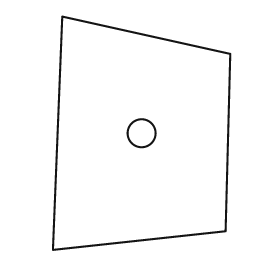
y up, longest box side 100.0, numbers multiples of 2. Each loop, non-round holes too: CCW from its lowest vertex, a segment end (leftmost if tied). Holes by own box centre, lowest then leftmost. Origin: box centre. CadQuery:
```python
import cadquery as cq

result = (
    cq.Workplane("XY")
    .moveTo(-38.0, -50.0)
    .lineTo(36.0, -42.0)
    .lineTo(38.0, 34.0)
    .lineTo(-34.0, 50.0)
    .close()
    .moveTo(0.0, 0.0)
    .circle(6.0)
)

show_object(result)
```